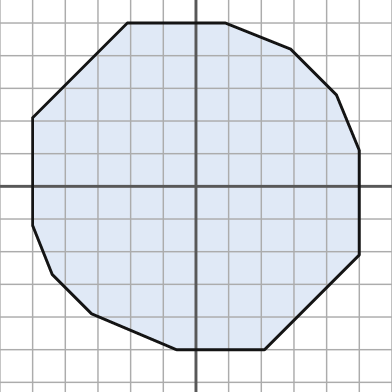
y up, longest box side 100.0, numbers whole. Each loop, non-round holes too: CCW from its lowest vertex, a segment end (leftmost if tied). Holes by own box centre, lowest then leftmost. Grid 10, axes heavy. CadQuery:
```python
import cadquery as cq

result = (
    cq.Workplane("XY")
    .moveTo(-6.0, -50.0)
    .lineTo(21.0, -50.0)
    .lineTo(50.0, -21.0)
    .lineTo(50.0, 11.0)
    .lineTo(43.0, 28.0)
    .lineTo(29.0, 42.0)
    .lineTo(9.0, 50.0)
    .lineTo(-21.0, 50.0)
    .lineTo(-50.0, 21.0)
    .lineTo(-50.0, -12.0)
    .lineTo(-44.0, -27.0)
    .lineTo(-32.0, -39.0)
    .close()
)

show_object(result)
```